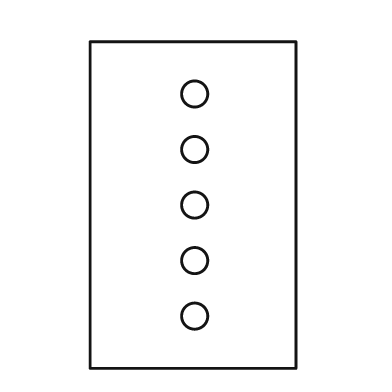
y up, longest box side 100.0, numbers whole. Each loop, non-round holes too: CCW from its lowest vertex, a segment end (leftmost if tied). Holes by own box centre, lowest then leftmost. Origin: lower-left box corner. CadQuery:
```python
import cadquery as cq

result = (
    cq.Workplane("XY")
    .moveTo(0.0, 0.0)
    .lineTo(63.0, 0.0)
    .lineTo(63.0, 100.0)
    .lineTo(0.0, 100.0)
    .close()
    .moveTo(32.0, 16.0)
    .circle(4.0)
    .moveTo(32.0, 33.0)
    .circle(4.0)
    .moveTo(32.0, 50.0)
    .circle(4.0)
    .moveTo(32.0, 67.0)
    .circle(4.0)
    .moveTo(32.0, 84.0)
    .circle(4.0)
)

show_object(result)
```